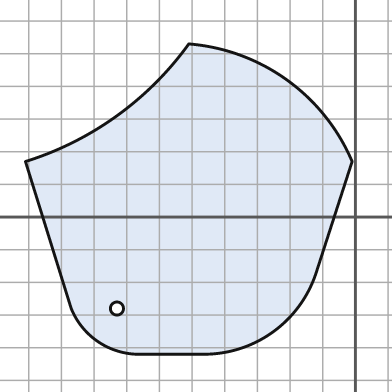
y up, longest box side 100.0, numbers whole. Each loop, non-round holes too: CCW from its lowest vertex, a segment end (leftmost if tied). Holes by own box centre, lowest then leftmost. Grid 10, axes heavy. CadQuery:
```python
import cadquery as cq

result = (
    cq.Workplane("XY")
    .moveTo(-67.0, -42.0)
    .lineTo(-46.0, -42.0)
    .threePointArc((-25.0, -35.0), (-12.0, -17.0))
    .lineTo(-1.0, 17.0)
    .threePointArc((-21.0, 42.0), (-51.0, 53.0))
    .threePointArc((-73.0, 31.0), (-101.0, 17.0))
    .lineTo(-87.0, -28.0)
    .threePointArc((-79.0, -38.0), (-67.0, -42.0))
    .close()
    .moveTo(-73.0, -28.0)
    .circle(2.0)
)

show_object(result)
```